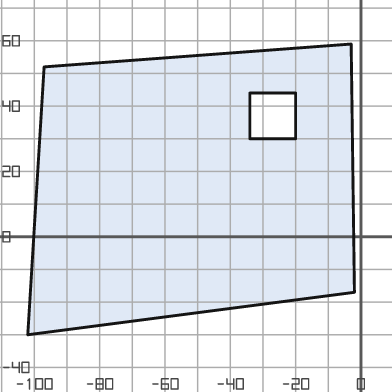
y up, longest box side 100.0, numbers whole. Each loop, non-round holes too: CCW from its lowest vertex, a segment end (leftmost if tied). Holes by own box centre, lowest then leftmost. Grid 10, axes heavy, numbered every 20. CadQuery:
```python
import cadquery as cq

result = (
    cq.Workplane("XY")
    .moveTo(-102.0, -30.0)
    .lineTo(-2.0, -17.0)
    .lineTo(-3.0, 59.0)
    .lineTo(-97.0, 52.0)
    .close()
    .moveTo(-34.0, 30.0)
    .lineTo(-20.0, 30.0)
    .lineTo(-20.0, 44.0)
    .lineTo(-34.0, 44.0)
    .close()
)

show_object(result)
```